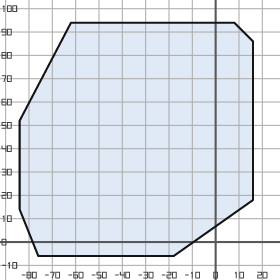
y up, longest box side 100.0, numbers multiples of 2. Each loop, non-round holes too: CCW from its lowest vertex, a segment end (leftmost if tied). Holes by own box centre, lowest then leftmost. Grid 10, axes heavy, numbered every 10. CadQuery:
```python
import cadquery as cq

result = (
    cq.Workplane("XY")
    .moveTo(-76.0, -6.0)
    .lineTo(-18.0, -6.0)
    .lineTo(16.0, 18.0)
    .lineTo(16.0, 86.0)
    .lineTo(8.0, 94.0)
    .lineTo(-62.0, 94.0)
    .lineTo(-84.0, 52.0)
    .lineTo(-84.0, 14.0)
    .close()
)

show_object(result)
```